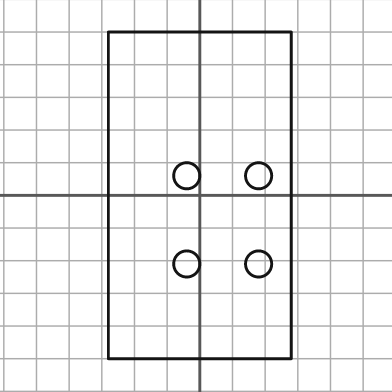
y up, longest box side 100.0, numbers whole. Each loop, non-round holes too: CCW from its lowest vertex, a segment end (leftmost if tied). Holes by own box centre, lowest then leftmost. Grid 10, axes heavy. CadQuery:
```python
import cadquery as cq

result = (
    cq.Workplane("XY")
    .moveTo(-28.0, -50.0)
    .lineTo(28.0, -50.0)
    .lineTo(28.0, 50.0)
    .lineTo(-28.0, 50.0)
    .close()
    .moveTo(-4.0, -21.0)
    .circle(4.0)
    .moveTo(18.0, -21.0)
    .circle(4.0)
    .moveTo(-4.0, 6.0)
    .circle(4.0)
    .moveTo(18.0, 6.0)
    .circle(4.0)
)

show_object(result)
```